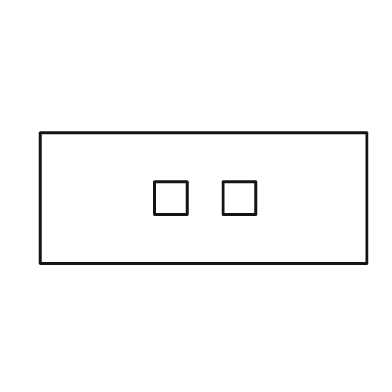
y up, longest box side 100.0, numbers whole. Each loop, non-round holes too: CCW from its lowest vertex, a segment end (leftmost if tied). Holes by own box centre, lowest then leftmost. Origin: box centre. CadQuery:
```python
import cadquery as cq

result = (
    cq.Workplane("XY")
    .moveTo(-50.0, -20.0)
    .lineTo(50.0, -20.0)
    .lineTo(50.0, 20.0)
    .lineTo(-50.0, 20.0)
    .close()
    .moveTo(-15.0, -5.0)
    .lineTo(-5.0, -5.0)
    .lineTo(-5.0, 5.0)
    .lineTo(-15.0, 5.0)
    .close()
    .moveTo(6.0, -5.0)
    .lineTo(16.0, -5.0)
    .lineTo(16.0, 5.0)
    .lineTo(6.0, 5.0)
    .close()
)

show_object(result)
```